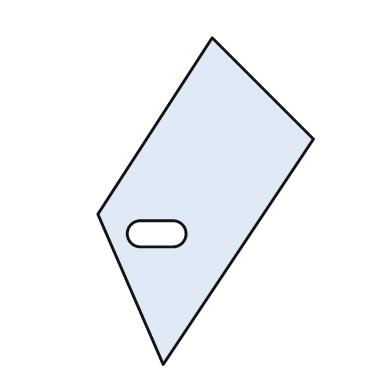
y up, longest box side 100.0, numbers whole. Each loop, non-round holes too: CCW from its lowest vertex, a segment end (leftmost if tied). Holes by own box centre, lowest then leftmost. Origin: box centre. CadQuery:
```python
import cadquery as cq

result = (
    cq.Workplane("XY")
    .moveTo(-13.0, -50.0)
    .lineTo(33.0, 19.0)
    .lineTo(2.0, 50.0)
    .lineTo(-33.0, -4.0)
    .close()
    .moveTo(-20.0, -14.0)
    .lineTo(-10.0, -14.0)
    .threePointArc((-6.0, -10.0), (-10.0, -6.0))
    .lineTo(-20.0, -6.0)
    .threePointArc((-24.0, -10.0), (-20.0, -14.0))
    .close()
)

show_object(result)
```